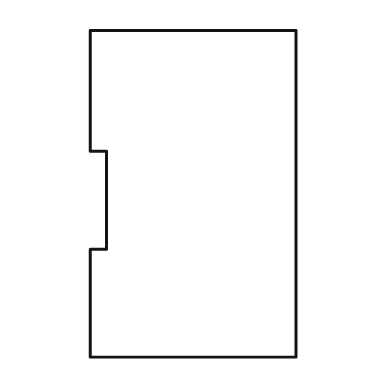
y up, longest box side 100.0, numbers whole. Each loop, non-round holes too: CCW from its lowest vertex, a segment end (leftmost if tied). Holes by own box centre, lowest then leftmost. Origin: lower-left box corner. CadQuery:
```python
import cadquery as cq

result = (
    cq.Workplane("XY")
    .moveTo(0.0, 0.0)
    .lineTo(63.0, 0.0)
    .lineTo(63.0, 100.0)
    .lineTo(0.0, 100.0)
    .lineTo(0.0, 63.0)
    .lineTo(5.0, 63.0)
    .lineTo(5.0, 33.0)
    .lineTo(0.0, 33.0)
    .close()
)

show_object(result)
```